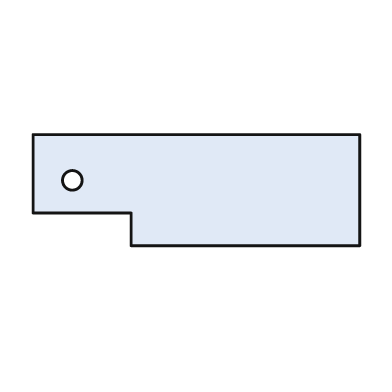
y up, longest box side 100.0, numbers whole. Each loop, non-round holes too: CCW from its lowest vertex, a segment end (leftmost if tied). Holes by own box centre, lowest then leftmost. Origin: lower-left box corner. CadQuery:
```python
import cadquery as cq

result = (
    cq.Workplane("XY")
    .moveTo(30.0, 0.0)
    .lineTo(100.0, 0.0)
    .lineTo(100.0, 34.0)
    .lineTo(0.0, 34.0)
    .lineTo(0.0, 10.0)
    .lineTo(30.0, 10.0)
    .close()
    .moveTo(12.0, 20.0)
    .circle(3.0)
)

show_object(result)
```